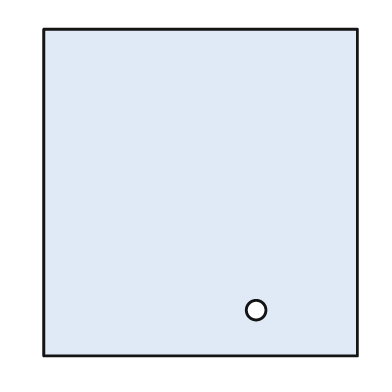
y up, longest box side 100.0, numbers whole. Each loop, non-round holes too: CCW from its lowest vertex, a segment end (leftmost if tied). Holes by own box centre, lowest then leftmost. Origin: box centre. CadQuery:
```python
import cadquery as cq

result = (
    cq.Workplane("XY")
    .moveTo(-48.0, -50.0)
    .lineTo(48.0, -50.0)
    .lineTo(48.0, 50.0)
    .lineTo(-48.0, 50.0)
    .close()
    .moveTo(17.0, -36.0)
    .circle(3.0)
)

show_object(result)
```